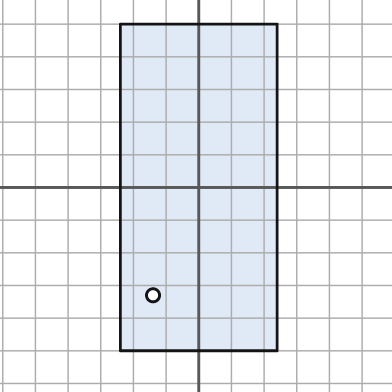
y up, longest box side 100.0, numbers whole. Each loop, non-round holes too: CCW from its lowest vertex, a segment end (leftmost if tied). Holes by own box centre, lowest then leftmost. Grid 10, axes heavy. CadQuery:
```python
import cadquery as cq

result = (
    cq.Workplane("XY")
    .moveTo(-24.0, -50.0)
    .lineTo(24.0, -50.0)
    .lineTo(24.0, 50.0)
    .lineTo(-24.0, 50.0)
    .close()
    .moveTo(-14.0, -33.0)
    .circle(2.0)
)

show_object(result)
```